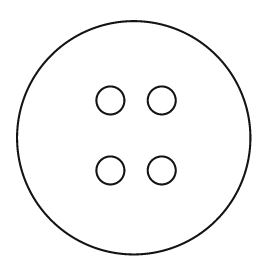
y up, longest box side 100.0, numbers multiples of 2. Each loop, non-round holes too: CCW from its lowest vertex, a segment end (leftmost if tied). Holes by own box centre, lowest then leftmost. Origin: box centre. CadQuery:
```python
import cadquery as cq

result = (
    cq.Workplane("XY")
    .moveTo(0.0, 0.0)
    .circle(50.0)
    .moveTo(-10.0, -14.0)
    .circle(6.0)
    .moveTo(12.0, -14.0)
    .circle(6.0)
    .moveTo(-10.0, 16.0)
    .circle(6.0)
    .moveTo(12.0, 16.0)
    .circle(6.0)
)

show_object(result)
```